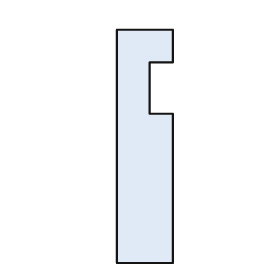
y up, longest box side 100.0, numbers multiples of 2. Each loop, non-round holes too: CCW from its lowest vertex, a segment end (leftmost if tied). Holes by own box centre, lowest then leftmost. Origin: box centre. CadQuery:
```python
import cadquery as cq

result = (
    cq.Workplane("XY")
    .moveTo(-12.0, -50.0)
    .lineTo(12.0, -50.0)
    .lineTo(12.0, 14.0)
    .lineTo(2.0, 14.0)
    .lineTo(2.0, 36.0)
    .lineTo(12.0, 36.0)
    .lineTo(12.0, 50.0)
    .lineTo(-12.0, 50.0)
    .close()
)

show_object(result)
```